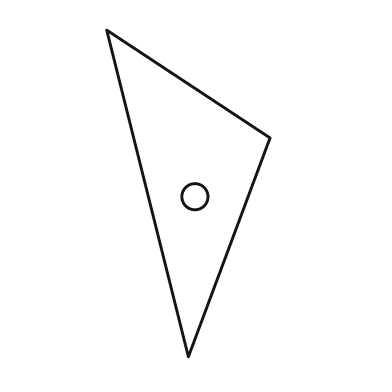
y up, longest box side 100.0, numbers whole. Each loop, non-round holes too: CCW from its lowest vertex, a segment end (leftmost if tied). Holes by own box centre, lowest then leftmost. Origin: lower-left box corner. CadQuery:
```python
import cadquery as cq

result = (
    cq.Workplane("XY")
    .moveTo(25.0, 0.0)
    .lineTo(50.0, 67.0)
    .lineTo(0.0, 100.0)
    .close()
    .moveTo(27.0, 49.0)
    .circle(4.0)
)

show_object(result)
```